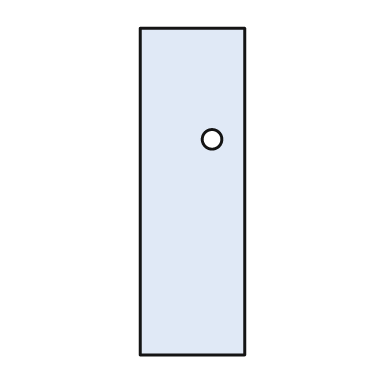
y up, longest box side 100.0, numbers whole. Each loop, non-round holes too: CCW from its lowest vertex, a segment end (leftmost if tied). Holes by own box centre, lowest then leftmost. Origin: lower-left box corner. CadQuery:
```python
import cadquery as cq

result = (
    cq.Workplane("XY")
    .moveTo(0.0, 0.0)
    .lineTo(32.0, 0.0)
    .lineTo(32.0, 100.0)
    .lineTo(0.0, 100.0)
    .close()
    .moveTo(22.0, 66.0)
    .circle(3.0)
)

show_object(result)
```